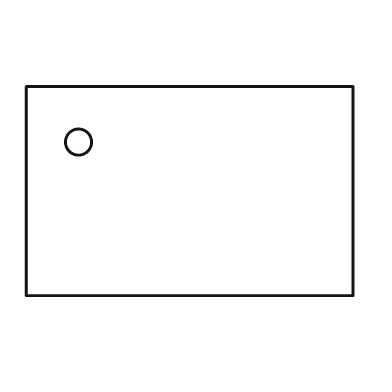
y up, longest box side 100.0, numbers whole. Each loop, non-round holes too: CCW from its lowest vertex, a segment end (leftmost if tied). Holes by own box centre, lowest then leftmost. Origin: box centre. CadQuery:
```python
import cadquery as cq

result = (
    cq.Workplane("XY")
    .moveTo(-50.0, -32.0)
    .lineTo(50.0, -32.0)
    .lineTo(50.0, 32.0)
    .lineTo(-50.0, 32.0)
    .close()
    .moveTo(-34.0, 15.0)
    .circle(4.0)
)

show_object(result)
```